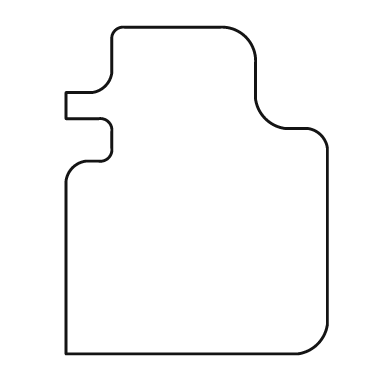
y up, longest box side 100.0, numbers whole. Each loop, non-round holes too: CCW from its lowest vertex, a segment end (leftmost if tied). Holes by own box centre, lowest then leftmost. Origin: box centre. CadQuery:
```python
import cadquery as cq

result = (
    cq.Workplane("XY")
    .moveTo(-40.0, -50.0)
    .lineTo(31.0, -50.0)
    .threePointArc((37.0, -47.0), (40.0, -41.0))
    .lineTo(40.0, 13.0)
    .threePointArc((38.0, 17.0), (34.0, 19.0))
    .lineTo(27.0, 19.0)
    .threePointArc((21.0, 22.0), (18.0, 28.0))
    .lineTo(18.0, 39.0)
    .threePointArc((15.0, 47.0), (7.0, 50.0))
    .lineTo(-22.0, 50.0)
    .threePointArc((-25.0, 49.0), (-26.0, 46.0))
    .lineTo(-26.0, 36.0)
    .threePointArc((-28.0, 32.0), (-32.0, 30.0))
    .lineTo(-40.0, 30.0)
    .lineTo(-40.0, 22.0)
    .lineTo(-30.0, 22.0)
    .threePointArc((-27.0, 21.0), (-26.0, 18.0))
    .lineTo(-26.0, 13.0)
    .threePointArc((-27.0, 10.0), (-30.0, 9.0))
    .lineTo(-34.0, 9.0)
    .threePointArc((-38.0, 7.0), (-40.0, 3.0))
    .close()
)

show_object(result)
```